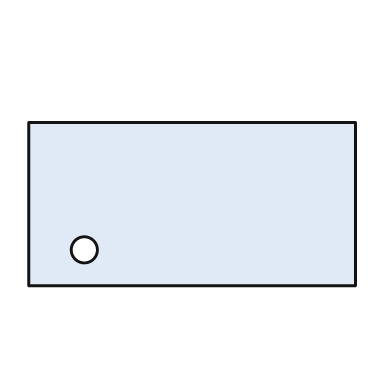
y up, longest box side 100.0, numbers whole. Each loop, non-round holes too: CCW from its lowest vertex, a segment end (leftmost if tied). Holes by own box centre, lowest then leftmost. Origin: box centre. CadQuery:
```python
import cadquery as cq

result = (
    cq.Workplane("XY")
    .moveTo(-50.0, -25.0)
    .lineTo(50.0, -25.0)
    .lineTo(50.0, 25.0)
    .lineTo(-50.0, 25.0)
    .close()
    .moveTo(-33.0, -14.0)
    .circle(4.0)
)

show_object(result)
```